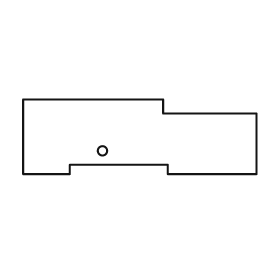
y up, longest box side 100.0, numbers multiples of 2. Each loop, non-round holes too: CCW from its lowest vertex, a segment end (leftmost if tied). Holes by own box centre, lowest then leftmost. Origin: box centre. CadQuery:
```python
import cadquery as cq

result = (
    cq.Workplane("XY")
    .moveTo(-50.0, -16.0)
    .lineTo(-30.0, -16.0)
    .lineTo(-30.0, -12.0)
    .lineTo(12.0, -12.0)
    .lineTo(12.0, -16.0)
    .lineTo(50.0, -16.0)
    .lineTo(50.0, 10.0)
    .lineTo(10.0, 10.0)
    .lineTo(10.0, 16.0)
    .lineTo(-50.0, 16.0)
    .close()
    .moveTo(-16.0, -6.0)
    .circle(2.0)
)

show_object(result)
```